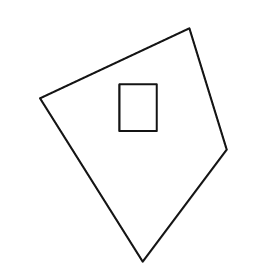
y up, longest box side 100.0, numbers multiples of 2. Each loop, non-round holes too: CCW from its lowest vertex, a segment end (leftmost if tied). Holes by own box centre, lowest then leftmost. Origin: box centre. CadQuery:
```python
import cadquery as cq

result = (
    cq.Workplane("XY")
    .moveTo(4.0, -50.0)
    .lineTo(40.0, -2.0)
    .lineTo(24.0, 50.0)
    .lineTo(-40.0, 20.0)
    .close()
    .moveTo(-6.0, 6.0)
    .lineTo(10.0, 6.0)
    .lineTo(10.0, 26.0)
    .lineTo(-6.0, 26.0)
    .close()
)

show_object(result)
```